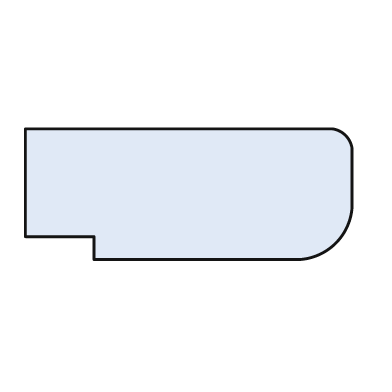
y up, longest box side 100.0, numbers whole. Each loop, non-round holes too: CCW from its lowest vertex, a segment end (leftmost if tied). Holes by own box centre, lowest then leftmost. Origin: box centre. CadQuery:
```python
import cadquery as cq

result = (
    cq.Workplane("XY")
    .moveTo(-29.0, -20.0)
    .lineTo(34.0, -20.0)
    .threePointArc((45.0, -15.0), (50.0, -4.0))
    .lineTo(50.0, 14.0)
    .threePointArc((48.0, 18.0), (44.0, 20.0))
    .lineTo(-50.0, 20.0)
    .lineTo(-50.0, -13.0)
    .lineTo(-29.0, -13.0)
    .close()
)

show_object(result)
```